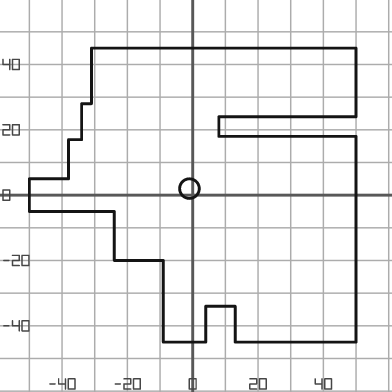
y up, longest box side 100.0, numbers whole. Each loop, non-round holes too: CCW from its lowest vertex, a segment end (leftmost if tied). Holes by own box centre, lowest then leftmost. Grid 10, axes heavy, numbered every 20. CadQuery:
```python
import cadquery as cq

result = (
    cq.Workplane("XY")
    .moveTo(-9.0, -45.0)
    .lineTo(4.0, -45.0)
    .lineTo(4.0, -34.0)
    .lineTo(13.0, -34.0)
    .lineTo(13.0, -45.0)
    .lineTo(50.0, -45.0)
    .lineTo(50.0, 18.0)
    .lineTo(8.0, 18.0)
    .lineTo(8.0, 24.0)
    .lineTo(50.0, 24.0)
    .lineTo(50.0, 45.0)
    .lineTo(-31.0, 45.0)
    .lineTo(-31.0, 28.0)
    .lineTo(-34.0, 28.0)
    .lineTo(-34.0, 17.0)
    .lineTo(-38.0, 17.0)
    .lineTo(-38.0, 5.0)
    .lineTo(-50.0, 5.0)
    .lineTo(-50.0, -5.0)
    .lineTo(-24.0, -5.0)
    .lineTo(-24.0, -20.0)
    .lineTo(-9.0, -20.0)
    .close()
    .moveTo(-1.0, 2.0)
    .circle(3.0)
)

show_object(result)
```